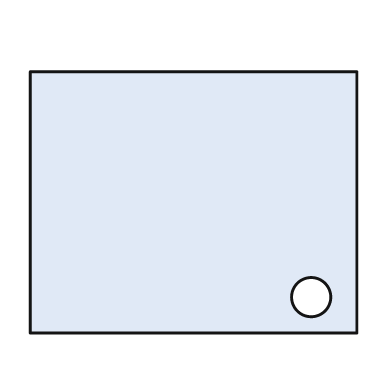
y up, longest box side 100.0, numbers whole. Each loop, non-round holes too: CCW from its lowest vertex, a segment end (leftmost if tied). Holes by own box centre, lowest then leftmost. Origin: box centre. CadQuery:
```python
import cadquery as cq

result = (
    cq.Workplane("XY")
    .moveTo(-50.0, -40.0)
    .lineTo(50.0, -40.0)
    .lineTo(50.0, 40.0)
    .lineTo(-50.0, 40.0)
    .close()
    .moveTo(36.0, -29.0)
    .circle(6.0)
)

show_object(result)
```